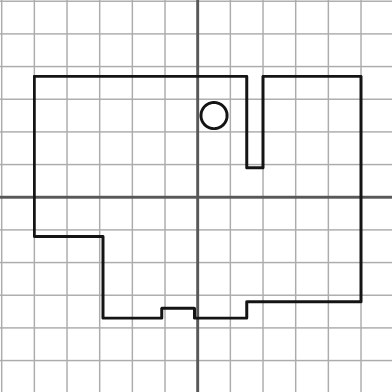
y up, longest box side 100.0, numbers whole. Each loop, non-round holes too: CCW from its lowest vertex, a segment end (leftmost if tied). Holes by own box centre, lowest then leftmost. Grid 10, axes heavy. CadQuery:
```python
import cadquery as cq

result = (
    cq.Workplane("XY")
    .moveTo(-29.0, -37.0)
    .lineTo(-11.0, -37.0)
    .lineTo(-11.0, -34.0)
    .lineTo(-1.0, -34.0)
    .lineTo(-1.0, -37.0)
    .lineTo(15.0, -37.0)
    .lineTo(15.0, -32.0)
    .lineTo(50.0, -32.0)
    .lineTo(50.0, 37.0)
    .lineTo(20.0, 37.0)
    .lineTo(20.0, 9.0)
    .lineTo(15.0, 9.0)
    .lineTo(15.0, 37.0)
    .lineTo(-50.0, 37.0)
    .lineTo(-50.0, -12.0)
    .lineTo(-29.0, -12.0)
    .close()
    .moveTo(5.0, 25.0)
    .circle(4.0)
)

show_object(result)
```